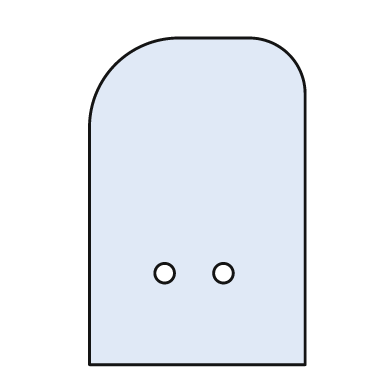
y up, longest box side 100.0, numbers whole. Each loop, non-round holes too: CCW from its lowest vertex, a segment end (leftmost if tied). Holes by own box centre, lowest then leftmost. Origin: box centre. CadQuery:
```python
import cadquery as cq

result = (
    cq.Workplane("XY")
    .moveTo(-33.0, -50.0)
    .lineTo(33.0, -50.0)
    .lineTo(33.0, 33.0)
    .threePointArc((28.0, 45.0), (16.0, 50.0))
    .lineTo(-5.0, 50.0)
    .threePointArc((-25.0, 42.0), (-33.0, 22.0))
    .close()
    .moveTo(-10.0, -22.0)
    .circle(3.0)
    .moveTo(8.0, -22.0)
    .circle(3.0)
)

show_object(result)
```